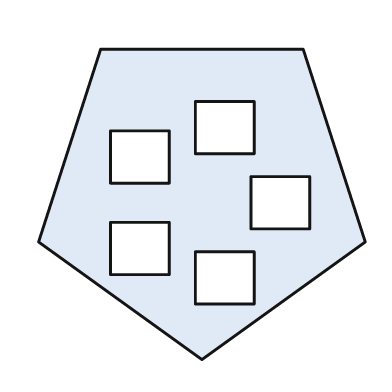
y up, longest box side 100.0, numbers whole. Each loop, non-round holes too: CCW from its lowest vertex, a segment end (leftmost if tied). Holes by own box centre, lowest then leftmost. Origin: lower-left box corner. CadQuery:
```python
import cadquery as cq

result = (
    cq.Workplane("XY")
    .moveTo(50.0, 0.0)
    .lineTo(100.0, 36.0)
    .lineTo(81.0, 95.0)
    .lineTo(19.0, 95.0)
    .lineTo(0.0, 36.0)
    .close()
    .moveTo(48.0, 17.0)
    .lineTo(66.0, 17.0)
    .lineTo(66.0, 33.0)
    .lineTo(48.0, 33.0)
    .close()
    .moveTo(22.0, 26.0)
    .lineTo(40.0, 26.0)
    .lineTo(40.0, 42.0)
    .lineTo(22.0, 42.0)
    .close()
    .moveTo(65.0, 40.0)
    .lineTo(83.0, 40.0)
    .lineTo(83.0, 56.0)
    .lineTo(65.0, 56.0)
    .close()
    .moveTo(22.0, 54.0)
    .lineTo(40.0, 54.0)
    .lineTo(40.0, 70.0)
    .lineTo(22.0, 70.0)
    .close()
    .moveTo(48.0, 63.0)
    .lineTo(66.0, 63.0)
    .lineTo(66.0, 79.0)
    .lineTo(48.0, 79.0)
    .close()
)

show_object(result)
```